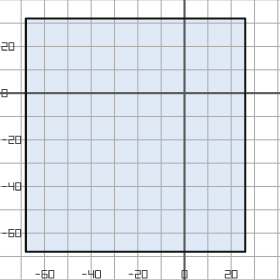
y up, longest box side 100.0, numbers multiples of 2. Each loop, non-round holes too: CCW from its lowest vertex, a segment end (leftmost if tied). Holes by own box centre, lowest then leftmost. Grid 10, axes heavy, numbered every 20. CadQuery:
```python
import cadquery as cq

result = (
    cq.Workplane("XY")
    .moveTo(-68.0, -68.0)
    .lineTo(26.0, -68.0)
    .lineTo(26.0, 32.0)
    .lineTo(-68.0, 32.0)
    .close()
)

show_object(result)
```